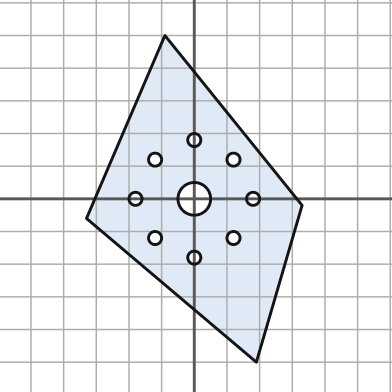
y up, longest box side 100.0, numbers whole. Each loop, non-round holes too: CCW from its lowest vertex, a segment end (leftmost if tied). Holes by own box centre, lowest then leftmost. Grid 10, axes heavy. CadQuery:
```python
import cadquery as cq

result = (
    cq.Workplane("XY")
    .moveTo(19.0, -50.0)
    .lineTo(33.0, -2.0)
    .lineTo(-9.0, 50.0)
    .lineTo(-33.0, -6.0)
    .close()
    .moveTo(0.0, -18.0)
    .circle(2.0)
    .moveTo(-12.0, -12.0)
    .circle(2.0)
    .moveTo(12.0, -12.0)
    .circle(2.0)
    .moveTo(-18.0, 0.0)
    .circle(2.0)
    .moveTo(0.0, 0.0)
    .circle(5.0)
    .moveTo(18.0, 0.0)
    .circle(2.0)
    .moveTo(-12.0, 12.0)
    .circle(2.0)
    .moveTo(12.0, 12.0)
    .circle(2.0)
    .moveTo(0.0, 18.0)
    .circle(2.0)
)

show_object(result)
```